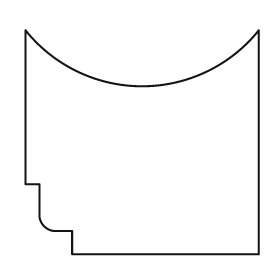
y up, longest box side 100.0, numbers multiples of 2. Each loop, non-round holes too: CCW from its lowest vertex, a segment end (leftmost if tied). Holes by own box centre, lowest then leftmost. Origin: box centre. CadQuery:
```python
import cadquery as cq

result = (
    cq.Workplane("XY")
    .moveTo(-30.0, -48.0)
    .lineTo(50.0, -48.0)
    .lineTo(50.0, 48.0)
    .threePointArc((0.0, 24.0), (-50.0, 48.0))
    .lineTo(-50.0, -18.0)
    .lineTo(-44.0, -18.0)
    .lineTo(-44.0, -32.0)
    .threePointArc((-42.0, -36.0), (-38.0, -38.0))
    .lineTo(-30.0, -38.0)
    .close()
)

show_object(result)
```